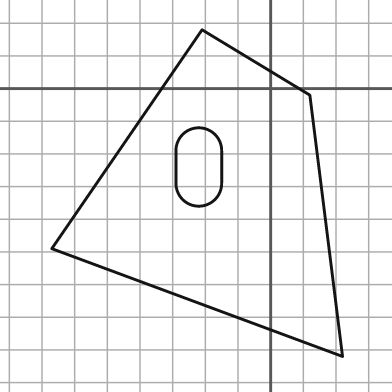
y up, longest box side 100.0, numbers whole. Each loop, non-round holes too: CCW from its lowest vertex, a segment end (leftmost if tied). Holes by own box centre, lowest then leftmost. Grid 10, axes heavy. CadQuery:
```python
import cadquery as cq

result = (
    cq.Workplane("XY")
    .moveTo(22.0, -82.0)
    .lineTo(12.0, -2.0)
    .lineTo(-21.0, 18.0)
    .lineTo(-67.0, -49.0)
    .close()
    .moveTo(-29.0, -29.0)
    .threePointArc((-22.0, -36.0), (-15.0, -29.0))
    .lineTo(-15.0, -19.0)
    .threePointArc((-22.0, -12.0), (-29.0, -19.0))
    .close()
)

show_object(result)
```